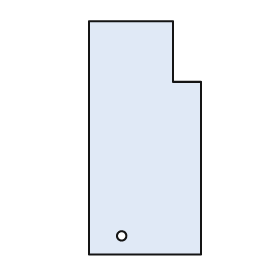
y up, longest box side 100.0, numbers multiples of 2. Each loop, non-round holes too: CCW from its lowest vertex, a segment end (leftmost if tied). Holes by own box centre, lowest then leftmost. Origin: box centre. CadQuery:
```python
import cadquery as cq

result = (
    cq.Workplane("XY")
    .moveTo(-24.0, -50.0)
    .lineTo(24.0, -50.0)
    .lineTo(24.0, 24.0)
    .lineTo(12.0, 24.0)
    .lineTo(12.0, 50.0)
    .lineTo(-24.0, 50.0)
    .close()
    .moveTo(-10.0, -42.0)
    .circle(2.0)
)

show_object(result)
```